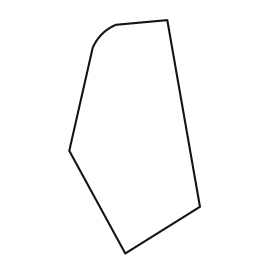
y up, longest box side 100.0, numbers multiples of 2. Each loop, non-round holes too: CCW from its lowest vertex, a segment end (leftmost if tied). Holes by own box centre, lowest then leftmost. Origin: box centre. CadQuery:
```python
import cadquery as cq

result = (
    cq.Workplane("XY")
    .moveTo(-4.0, -50.0)
    .lineTo(28.0, -30.0)
    .lineTo(14.0, 50.0)
    .lineTo(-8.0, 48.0)
    .threePointArc((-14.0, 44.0), (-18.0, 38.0))
    .lineTo(-28.0, -6.0)
    .close()
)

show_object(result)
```